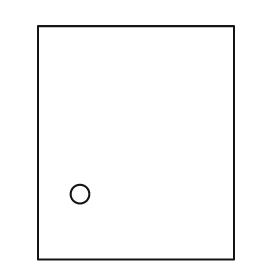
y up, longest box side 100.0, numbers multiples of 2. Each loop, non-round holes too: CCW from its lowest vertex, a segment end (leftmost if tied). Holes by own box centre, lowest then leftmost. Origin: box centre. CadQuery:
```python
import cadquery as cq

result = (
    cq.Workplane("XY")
    .moveTo(-42.0, -50.0)
    .lineTo(42.0, -50.0)
    .lineTo(42.0, 50.0)
    .lineTo(-42.0, 50.0)
    .close()
    .moveTo(-24.0, -22.0)
    .circle(4.0)
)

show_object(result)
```